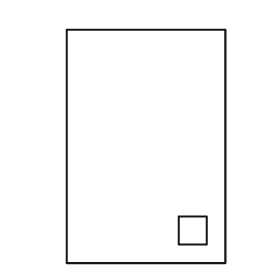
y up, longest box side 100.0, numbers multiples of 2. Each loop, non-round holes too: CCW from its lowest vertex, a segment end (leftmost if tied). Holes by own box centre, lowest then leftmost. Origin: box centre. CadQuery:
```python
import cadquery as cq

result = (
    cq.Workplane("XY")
    .moveTo(-34.0, -50.0)
    .lineTo(34.0, -50.0)
    .lineTo(34.0, 50.0)
    .lineTo(-34.0, 50.0)
    .close()
    .moveTo(14.0, -42.0)
    .lineTo(26.0, -42.0)
    .lineTo(26.0, -30.0)
    .lineTo(14.0, -30.0)
    .close()
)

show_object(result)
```